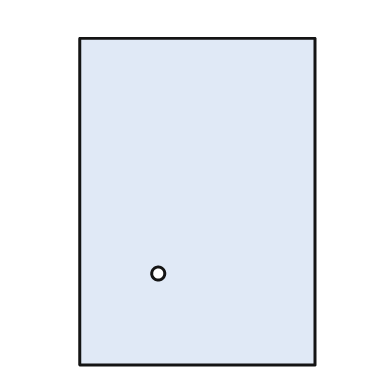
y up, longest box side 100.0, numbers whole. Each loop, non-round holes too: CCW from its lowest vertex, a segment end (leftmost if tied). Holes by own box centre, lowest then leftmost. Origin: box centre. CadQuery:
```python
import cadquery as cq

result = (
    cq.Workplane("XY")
    .moveTo(-36.0, -50.0)
    .lineTo(36.0, -50.0)
    .lineTo(36.0, 50.0)
    .lineTo(-36.0, 50.0)
    .close()
    .moveTo(-12.0, -22.0)
    .circle(2.0)
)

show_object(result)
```